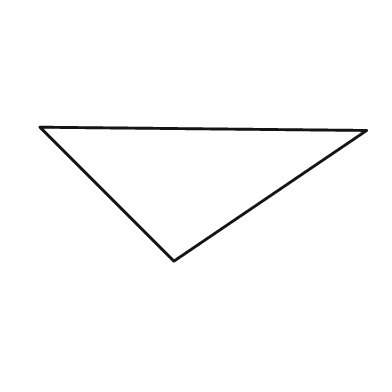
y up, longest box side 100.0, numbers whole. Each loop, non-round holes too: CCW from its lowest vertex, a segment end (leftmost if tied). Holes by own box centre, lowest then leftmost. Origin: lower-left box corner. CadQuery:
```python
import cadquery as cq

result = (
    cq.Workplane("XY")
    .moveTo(41.0, 0.0)
    .lineTo(100.0, 40.0)
    .lineTo(0.0, 41.0)
    .close()
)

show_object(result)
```